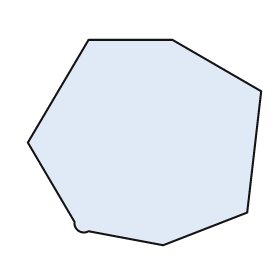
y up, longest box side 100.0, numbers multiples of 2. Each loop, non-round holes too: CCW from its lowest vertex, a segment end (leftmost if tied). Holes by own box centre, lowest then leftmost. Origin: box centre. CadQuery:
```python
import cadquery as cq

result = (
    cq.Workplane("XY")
    .moveTo(8.0, -44.0)
    .lineTo(44.0, -30.0)
    .lineTo(50.0, 22.0)
    .lineTo(12.0, 44.0)
    .lineTo(-24.0, 44.0)
    .lineTo(-50.0, 0.0)
    .lineTo(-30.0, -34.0)
    .threePointArc((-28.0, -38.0), (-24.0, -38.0))
    .close()
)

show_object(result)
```